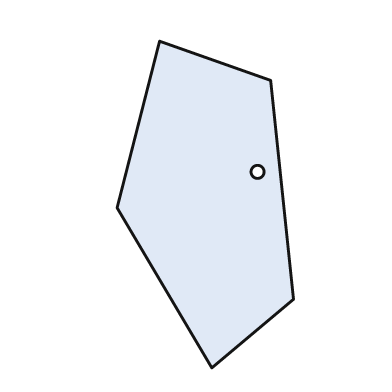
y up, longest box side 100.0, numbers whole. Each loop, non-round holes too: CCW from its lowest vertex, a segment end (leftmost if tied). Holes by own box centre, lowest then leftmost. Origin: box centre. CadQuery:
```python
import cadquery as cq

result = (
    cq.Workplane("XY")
    .moveTo(2.0, -50.0)
    .lineTo(27.0, -29.0)
    .lineTo(20.0, 38.0)
    .lineTo(-14.0, 50.0)
    .lineTo(-27.0, -1.0)
    .close()
    .moveTo(16.0, 10.0)
    .circle(2.0)
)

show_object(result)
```